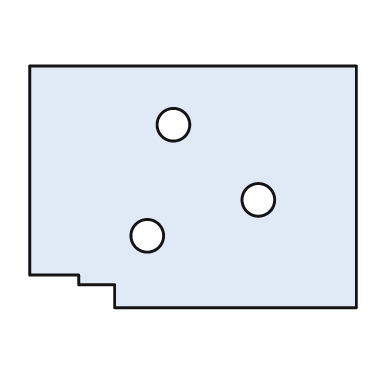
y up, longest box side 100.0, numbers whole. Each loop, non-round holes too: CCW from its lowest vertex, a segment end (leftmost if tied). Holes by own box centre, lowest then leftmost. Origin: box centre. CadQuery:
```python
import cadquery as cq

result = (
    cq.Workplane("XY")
    .moveTo(-24.0, -37.0)
    .lineTo(50.0, -37.0)
    .lineTo(50.0, 37.0)
    .lineTo(-50.0, 37.0)
    .lineTo(-50.0, -27.0)
    .lineTo(-35.0, -27.0)
    .lineTo(-35.0, -30.0)
    .lineTo(-24.0, -30.0)
    .close()
    .moveTo(-14.0, -15.0)
    .circle(5.0)
    .moveTo(20.0, -4.0)
    .circle(5.0)
    .moveTo(-6.0, 19.0)
    .circle(5.0)
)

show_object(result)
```